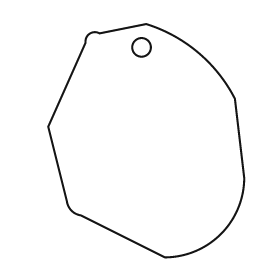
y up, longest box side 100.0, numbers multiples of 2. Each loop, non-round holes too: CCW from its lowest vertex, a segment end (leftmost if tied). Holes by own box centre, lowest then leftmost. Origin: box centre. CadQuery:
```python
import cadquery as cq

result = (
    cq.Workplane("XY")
    .moveTo(8.0, -50.0)
    .threePointArc((32.0, -40.0), (42.0, -16.0))
    .lineTo(38.0, 18.0)
    .threePointArc((22.0, 38.0), (0.0, 50.0))
    .lineTo(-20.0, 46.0)
    .threePointArc((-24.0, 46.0), (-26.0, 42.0))
    .lineTo(-42.0, 6.0)
    .lineTo(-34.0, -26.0)
    .threePointArc((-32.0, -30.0), (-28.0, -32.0))
    .close()
    .moveTo(-2.0, 40.0)
    .circle(4.0)
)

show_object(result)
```